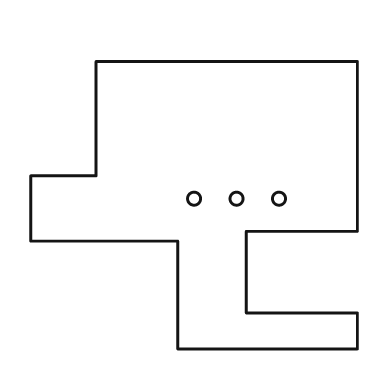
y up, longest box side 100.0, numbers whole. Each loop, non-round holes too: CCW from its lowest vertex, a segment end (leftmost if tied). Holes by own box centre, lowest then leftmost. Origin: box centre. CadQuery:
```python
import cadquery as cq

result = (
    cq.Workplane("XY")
    .moveTo(-5.0, -44.0)
    .lineTo(50.0, -44.0)
    .lineTo(50.0, -33.0)
    .lineTo(16.0, -33.0)
    .lineTo(16.0, -8.0)
    .lineTo(50.0, -8.0)
    .lineTo(50.0, 44.0)
    .lineTo(-30.0, 44.0)
    .lineTo(-30.0, 9.0)
    .lineTo(-50.0, 9.0)
    .lineTo(-50.0, -11.0)
    .lineTo(-5.0, -11.0)
    .close()
    .moveTo(0.0, 2.0)
    .circle(2.0)
    .moveTo(13.0, 2.0)
    .circle(2.0)
    .moveTo(26.0, 2.0)
    .circle(2.0)
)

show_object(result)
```